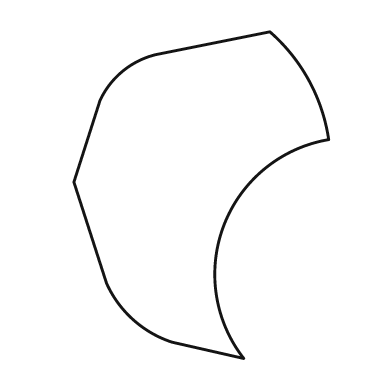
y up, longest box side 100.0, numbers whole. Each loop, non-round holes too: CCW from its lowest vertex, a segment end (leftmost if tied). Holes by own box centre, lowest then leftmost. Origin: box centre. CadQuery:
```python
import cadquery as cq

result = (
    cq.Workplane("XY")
    .moveTo(13.0, -50.0)
    .threePointArc((7.0, -9.0), (39.0, 17.0))
    .threePointArc((33.0, 35.0), (21.0, 50.0))
    .lineTo(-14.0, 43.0)
    .threePointArc((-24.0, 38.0), (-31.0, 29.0))
    .lineTo(-39.0, 4.0)
    .lineTo(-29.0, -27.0)
    .threePointArc((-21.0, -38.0), (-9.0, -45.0))
    .close()
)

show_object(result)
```